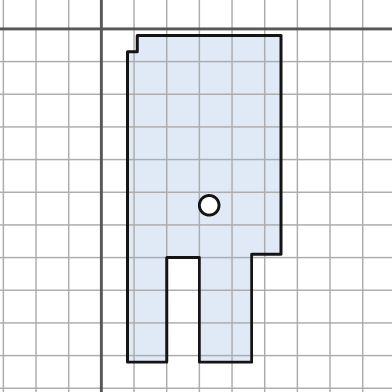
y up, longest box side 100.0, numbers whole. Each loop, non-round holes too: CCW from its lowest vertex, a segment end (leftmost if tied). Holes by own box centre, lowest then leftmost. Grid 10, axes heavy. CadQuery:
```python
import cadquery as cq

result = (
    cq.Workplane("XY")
    .moveTo(8.0, -102.0)
    .lineTo(20.0, -102.0)
    .lineTo(20.0, -70.0)
    .lineTo(30.0, -70.0)
    .lineTo(30.0, -102.0)
    .lineTo(46.0, -102.0)
    .lineTo(46.0, -69.0)
    .lineTo(55.0, -69.0)
    .lineTo(55.0, -2.0)
    .lineTo(11.0, -2.0)
    .lineTo(11.0, -7.0)
    .lineTo(8.0, -7.0)
    .close()
    .moveTo(33.0, -54.0)
    .circle(3.0)
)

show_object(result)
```